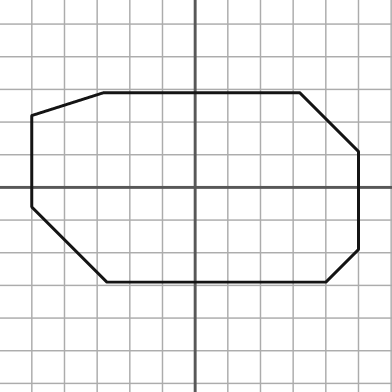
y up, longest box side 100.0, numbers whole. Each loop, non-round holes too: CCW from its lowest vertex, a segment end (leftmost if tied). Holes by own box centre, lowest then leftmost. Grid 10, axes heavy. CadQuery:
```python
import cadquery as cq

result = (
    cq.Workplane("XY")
    .moveTo(-27.0, -29.0)
    .lineTo(40.0, -29.0)
    .lineTo(50.0, -19.0)
    .lineTo(50.0, 11.0)
    .lineTo(32.0, 29.0)
    .lineTo(-28.0, 29.0)
    .lineTo(-50.0, 22.0)
    .lineTo(-50.0, -6.0)
    .close()
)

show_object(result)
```